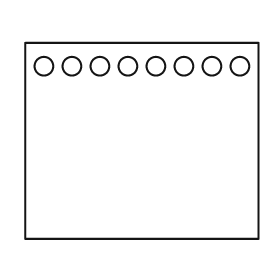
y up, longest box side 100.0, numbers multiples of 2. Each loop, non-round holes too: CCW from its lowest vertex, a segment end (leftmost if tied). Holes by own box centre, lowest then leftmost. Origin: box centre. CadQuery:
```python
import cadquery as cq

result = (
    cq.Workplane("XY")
    .moveTo(-50.0, -42.0)
    .lineTo(50.0, -42.0)
    .lineTo(50.0, 42.0)
    .lineTo(-50.0, 42.0)
    .close()
    .moveTo(-42.0, 32.0)
    .circle(4.0)
    .moveTo(-30.0, 32.0)
    .circle(4.0)
    .moveTo(-18.0, 32.0)
    .circle(4.0)
    .moveTo(-6.0, 32.0)
    .circle(4.0)
    .moveTo(6.0, 32.0)
    .circle(4.0)
    .moveTo(18.0, 32.0)
    .circle(4.0)
    .moveTo(30.0, 32.0)
    .circle(4.0)
    .moveTo(42.0, 32.0)
    .circle(4.0)
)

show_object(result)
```